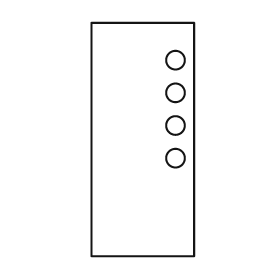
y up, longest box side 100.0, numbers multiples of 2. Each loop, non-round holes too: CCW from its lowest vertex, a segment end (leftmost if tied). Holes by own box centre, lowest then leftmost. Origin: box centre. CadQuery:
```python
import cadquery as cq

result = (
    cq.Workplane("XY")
    .moveTo(-22.0, -50.0)
    .lineTo(22.0, -50.0)
    .lineTo(22.0, 50.0)
    .lineTo(-22.0, 50.0)
    .close()
    .moveTo(14.0, -8.0)
    .circle(4.0)
    .moveTo(14.0, 6.0)
    .circle(4.0)
    .moveTo(14.0, 20.0)
    .circle(4.0)
    .moveTo(14.0, 34.0)
    .circle(4.0)
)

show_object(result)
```